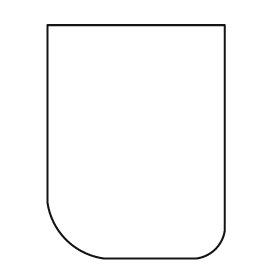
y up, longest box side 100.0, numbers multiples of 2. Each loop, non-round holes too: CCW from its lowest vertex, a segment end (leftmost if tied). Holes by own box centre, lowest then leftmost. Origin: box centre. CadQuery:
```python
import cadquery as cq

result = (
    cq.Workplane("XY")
    .moveTo(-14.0, -50.0)
    .lineTo(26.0, -50.0)
    .threePointArc((34.0, -46.0), (38.0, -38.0))
    .lineTo(38.0, 50.0)
    .lineTo(-38.0, 50.0)
    .lineTo(-38.0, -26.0)
    .threePointArc((-30.0, -42.0), (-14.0, -50.0))
    .close()
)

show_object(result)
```